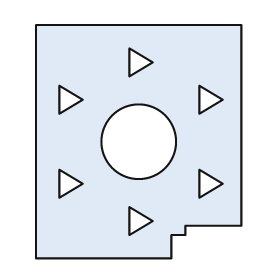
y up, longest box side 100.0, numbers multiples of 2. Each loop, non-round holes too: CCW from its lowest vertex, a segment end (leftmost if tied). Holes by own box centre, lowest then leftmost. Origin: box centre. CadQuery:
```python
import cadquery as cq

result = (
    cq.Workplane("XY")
    .moveTo(-44.0, -50.0)
    .lineTo(14.0, -50.0)
    .lineTo(14.0, -40.0)
    .lineTo(20.0, -40.0)
    .lineTo(20.0, -36.0)
    .lineTo(44.0, -36.0)
    .lineTo(44.0, 50.0)
    .lineTo(-44.0, 50.0)
    .close()
    .moveTo(-4.0, -40.0)
    .lineTo(6.0, -34.0)
    .lineTo(-4.0, -28.0)
    .close()
    .moveTo(-34.0, -24.0)
    .lineTo(-24.0, -18.0)
    .lineTo(-34.0, -12.0)
    .close()
    .moveTo(26.0, -24.0)
    .lineTo(36.0, -18.0)
    .lineTo(26.0, -12.0)
    .close()
    .moveTo(0.0, 0.0)
    .circle(16.0)
    .moveTo(-34.0, 12.0)
    .lineTo(-24.0, 18.0)
    .lineTo(-34.0, 24.0)
    .close()
    .moveTo(26.0, 12.0)
    .lineTo(36.0, 18.0)
    .lineTo(26.0, 24.0)
    .close()
    .moveTo(-4.0, 28.0)
    .lineTo(6.0, 34.0)
    .lineTo(-4.0, 40.0)
    .close()
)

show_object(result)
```